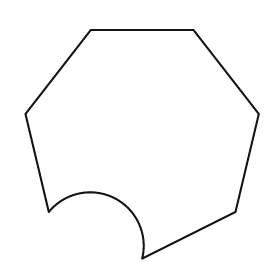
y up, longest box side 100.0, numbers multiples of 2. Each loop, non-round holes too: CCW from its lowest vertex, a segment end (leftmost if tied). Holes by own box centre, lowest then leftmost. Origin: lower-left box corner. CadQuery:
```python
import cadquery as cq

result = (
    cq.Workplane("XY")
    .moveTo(50.0, 0.0)
    .lineTo(90.0, 20.0)
    .lineTo(100.0, 62.0)
    .lineTo(72.0, 98.0)
    .lineTo(28.0, 98.0)
    .lineTo(0.0, 62.0)
    .lineTo(10.0, 20.0)
    .threePointArc((38.0, 26.0), (50.0, 0.0))
    .close()
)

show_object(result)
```